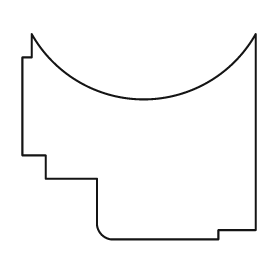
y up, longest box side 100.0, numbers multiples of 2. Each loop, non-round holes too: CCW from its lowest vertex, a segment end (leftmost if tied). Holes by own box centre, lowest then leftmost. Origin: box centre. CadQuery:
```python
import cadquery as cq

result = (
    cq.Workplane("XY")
    .moveTo(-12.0, -44.0)
    .lineTo(34.0, -44.0)
    .lineTo(34.0, -40.0)
    .lineTo(50.0, -40.0)
    .lineTo(50.0, 44.0)
    .threePointArc((2.0, 16.0), (-46.0, 44.0))
    .lineTo(-46.0, 34.0)
    .lineTo(-50.0, 34.0)
    .lineTo(-50.0, -8.0)
    .lineTo(-40.0, -8.0)
    .lineTo(-40.0, -18.0)
    .lineTo(-18.0, -18.0)
    .lineTo(-18.0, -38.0)
    .threePointArc((-16.0, -42.0), (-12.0, -44.0))
    .close()
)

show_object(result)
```